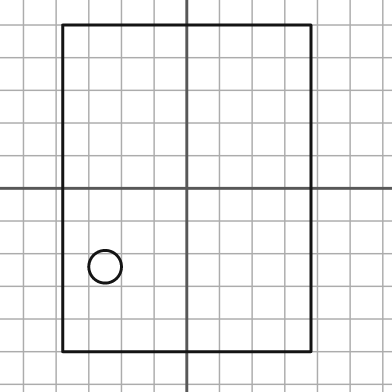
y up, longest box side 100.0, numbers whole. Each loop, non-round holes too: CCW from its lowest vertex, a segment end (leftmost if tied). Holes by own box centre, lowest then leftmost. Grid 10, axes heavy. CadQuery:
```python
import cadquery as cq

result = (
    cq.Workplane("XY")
    .moveTo(-38.0, -50.0)
    .lineTo(38.0, -50.0)
    .lineTo(38.0, 50.0)
    .lineTo(-38.0, 50.0)
    .close()
    .moveTo(-25.0, -24.0)
    .circle(5.0)
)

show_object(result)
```